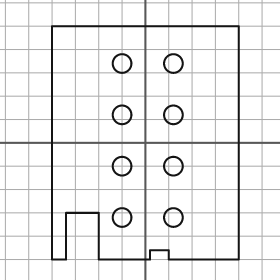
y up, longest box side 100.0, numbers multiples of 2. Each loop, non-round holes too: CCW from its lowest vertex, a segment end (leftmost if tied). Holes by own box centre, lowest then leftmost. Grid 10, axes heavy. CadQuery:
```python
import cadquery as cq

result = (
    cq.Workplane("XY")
    .moveTo(-40.0, -50.0)
    .lineTo(-34.0, -50.0)
    .lineTo(-34.0, -30.0)
    .lineTo(-20.0, -30.0)
    .lineTo(-20.0, -50.0)
    .lineTo(2.0, -50.0)
    .lineTo(2.0, -46.0)
    .lineTo(10.0, -46.0)
    .lineTo(10.0, -50.0)
    .lineTo(40.0, -50.0)
    .lineTo(40.0, 50.0)
    .lineTo(-40.0, 50.0)
    .close()
    .moveTo(-10.0, -32.0)
    .circle(4.0)
    .moveTo(12.0, -32.0)
    .circle(4.0)
    .moveTo(-10.0, -10.0)
    .circle(4.0)
    .moveTo(12.0, -10.0)
    .circle(4.0)
    .moveTo(-10.0, 12.0)
    .circle(4.0)
    .moveTo(12.0, 12.0)
    .circle(4.0)
    .moveTo(-10.0, 34.0)
    .circle(4.0)
    .moveTo(12.0, 34.0)
    .circle(4.0)
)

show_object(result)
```